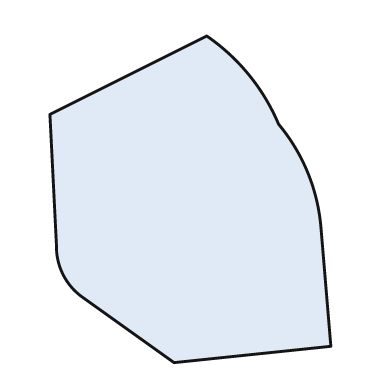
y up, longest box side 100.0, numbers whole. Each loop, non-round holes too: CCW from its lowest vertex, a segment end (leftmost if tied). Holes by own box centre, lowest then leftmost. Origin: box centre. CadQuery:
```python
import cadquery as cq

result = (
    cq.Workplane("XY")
    .moveTo(-5.0, -50.0)
    .lineTo(43.0, -45.0)
    .lineTo(40.0, -9.0)
    .threePointArc((36.0, 8.0), (27.0, 23.0))
    .threePointArc((18.0, 38.0), (5.0, 50.0))
    .lineTo(-43.0, 26.0)
    .lineTo(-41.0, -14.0)
    .threePointArc((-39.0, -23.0), (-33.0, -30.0))
    .close()
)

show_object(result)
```